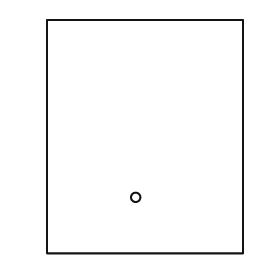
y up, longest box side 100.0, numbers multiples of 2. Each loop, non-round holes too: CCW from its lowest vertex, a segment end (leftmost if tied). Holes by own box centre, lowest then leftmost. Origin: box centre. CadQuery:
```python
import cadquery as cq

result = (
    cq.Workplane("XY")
    .moveTo(-42.0, -50.0)
    .lineTo(42.0, -50.0)
    .lineTo(42.0, 50.0)
    .lineTo(-42.0, 50.0)
    .close()
    .moveTo(-4.0, -26.0)
    .circle(2.0)
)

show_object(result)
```